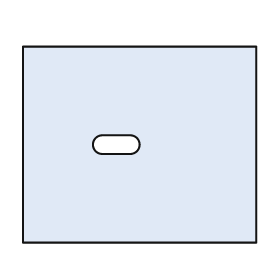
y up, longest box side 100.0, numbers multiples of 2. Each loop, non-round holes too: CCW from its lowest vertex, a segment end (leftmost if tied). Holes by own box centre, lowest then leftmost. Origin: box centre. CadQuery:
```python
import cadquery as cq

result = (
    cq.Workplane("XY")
    .moveTo(-50.0, -42.0)
    .lineTo(50.0, -42.0)
    .lineTo(50.0, 42.0)
    .lineTo(-50.0, 42.0)
    .close()
    .moveTo(-16.0, -4.0)
    .lineTo(-4.0, -4.0)
    .threePointArc((0.0, 0.0), (-4.0, 4.0))
    .lineTo(-16.0, 4.0)
    .threePointArc((-20.0, 0.0), (-16.0, -4.0))
    .close()
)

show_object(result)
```